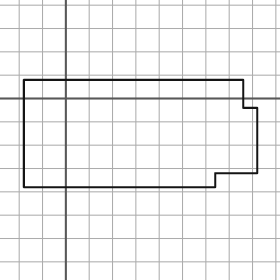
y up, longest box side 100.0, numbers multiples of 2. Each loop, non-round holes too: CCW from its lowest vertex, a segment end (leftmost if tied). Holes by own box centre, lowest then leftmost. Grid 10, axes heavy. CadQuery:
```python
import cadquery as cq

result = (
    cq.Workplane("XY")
    .moveTo(-18.0, -38.0)
    .lineTo(64.0, -38.0)
    .lineTo(64.0, -32.0)
    .lineTo(82.0, -32.0)
    .lineTo(82.0, -4.0)
    .lineTo(76.0, -4.0)
    .lineTo(76.0, 8.0)
    .lineTo(-18.0, 8.0)
    .close()
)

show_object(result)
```